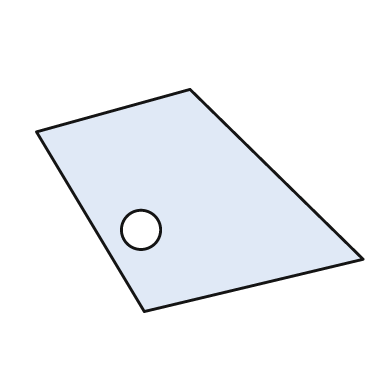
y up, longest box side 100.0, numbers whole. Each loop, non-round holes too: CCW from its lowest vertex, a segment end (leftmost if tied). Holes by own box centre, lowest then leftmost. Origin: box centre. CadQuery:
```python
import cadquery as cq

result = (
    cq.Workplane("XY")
    .moveTo(-17.0, -34.0)
    .lineTo(50.0, -18.0)
    .lineTo(-3.0, 34.0)
    .lineTo(-50.0, 21.0)
    .close()
    .moveTo(-18.0, -9.0)
    .circle(6.0)
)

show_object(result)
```